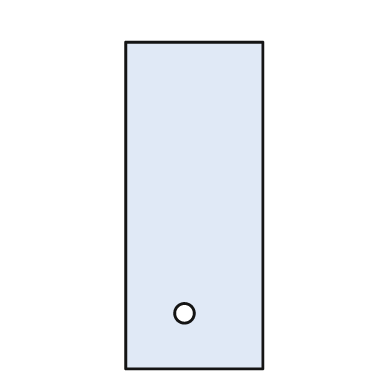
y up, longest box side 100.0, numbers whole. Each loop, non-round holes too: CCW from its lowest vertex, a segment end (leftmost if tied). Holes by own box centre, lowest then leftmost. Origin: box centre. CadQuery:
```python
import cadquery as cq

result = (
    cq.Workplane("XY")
    .moveTo(-21.0, -50.0)
    .lineTo(21.0, -50.0)
    .lineTo(21.0, 50.0)
    .lineTo(-21.0, 50.0)
    .close()
    .moveTo(-3.0, -33.0)
    .circle(3.0)
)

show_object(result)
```